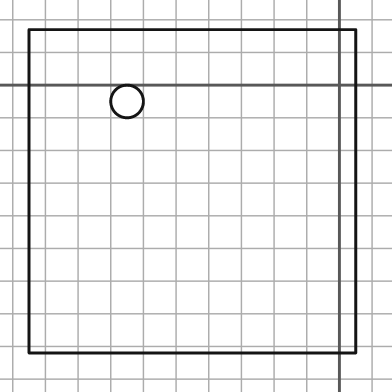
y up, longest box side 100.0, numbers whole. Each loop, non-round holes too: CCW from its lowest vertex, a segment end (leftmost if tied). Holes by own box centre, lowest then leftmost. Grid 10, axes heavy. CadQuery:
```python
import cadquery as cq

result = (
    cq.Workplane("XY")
    .moveTo(-95.0, -82.0)
    .lineTo(5.0, -82.0)
    .lineTo(5.0, 17.0)
    .lineTo(-95.0, 17.0)
    .close()
    .moveTo(-65.0, -5.0)
    .circle(5.0)
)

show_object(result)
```